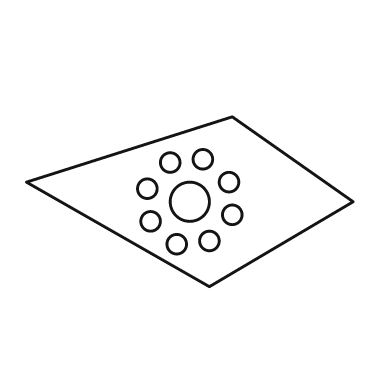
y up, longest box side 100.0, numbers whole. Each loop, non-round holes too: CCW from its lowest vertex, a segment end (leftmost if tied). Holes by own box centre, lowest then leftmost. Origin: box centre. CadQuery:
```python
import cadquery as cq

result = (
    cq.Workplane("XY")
    .moveTo(6.0, -26.0)
    .lineTo(50.0, 0.0)
    .lineTo(13.0, 26.0)
    .lineTo(-50.0, 6.0)
    .close()
    .moveTo(-4.0, -13.0)
    .circle(3.0)
    .moveTo(6.0, -12.0)
    .circle(3.0)
    .moveTo(-12.0, -6.0)
    .circle(3.0)
    .moveTo(13.0, -4.0)
    .circle(3.0)
    .moveTo(0.0, 0.0)
    .circle(6.0)
    .moveTo(-13.0, 4.0)
    .circle(3.0)
    .moveTo(12.0, 6.0)
    .circle(3.0)
    .moveTo(-6.0, 12.0)
    .circle(3.0)
    .moveTo(4.0, 13.0)
    .circle(3.0)
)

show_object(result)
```